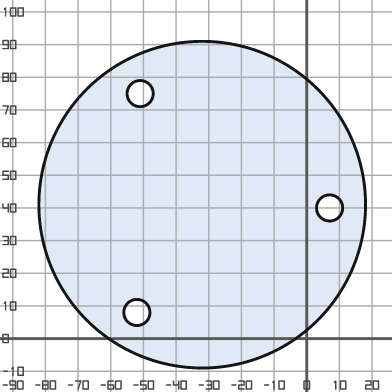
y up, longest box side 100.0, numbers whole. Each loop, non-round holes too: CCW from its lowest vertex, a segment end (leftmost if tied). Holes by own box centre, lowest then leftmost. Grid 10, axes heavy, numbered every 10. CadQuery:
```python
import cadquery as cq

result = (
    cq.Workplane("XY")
    .moveTo(-32.0, 41.0)
    .circle(50.0)
    .moveTo(-52.0, 8.0)
    .circle(4.0)
    .moveTo(7.0, 40.0)
    .circle(4.0)
    .moveTo(-51.0, 75.0)
    .circle(4.0)
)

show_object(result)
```